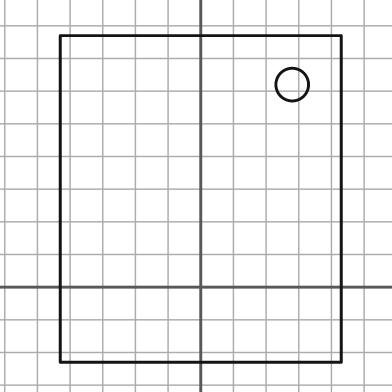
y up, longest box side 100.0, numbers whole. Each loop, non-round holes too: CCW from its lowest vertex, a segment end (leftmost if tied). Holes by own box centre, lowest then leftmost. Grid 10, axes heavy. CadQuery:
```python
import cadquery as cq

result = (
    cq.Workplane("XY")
    .moveTo(-43.0, -23.0)
    .lineTo(43.0, -23.0)
    .lineTo(43.0, 77.0)
    .lineTo(-43.0, 77.0)
    .close()
    .moveTo(28.0, 62.0)
    .circle(5.0)
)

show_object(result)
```